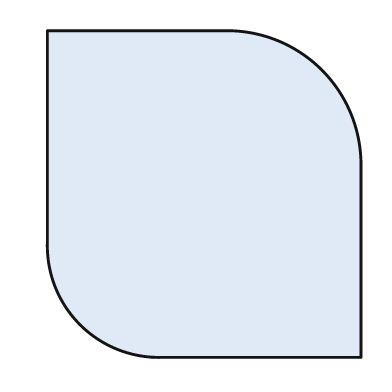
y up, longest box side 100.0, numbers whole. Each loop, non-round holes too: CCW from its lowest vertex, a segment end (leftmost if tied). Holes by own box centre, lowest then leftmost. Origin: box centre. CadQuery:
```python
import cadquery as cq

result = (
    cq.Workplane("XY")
    .moveTo(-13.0, -50.0)
    .lineTo(48.0, -50.0)
    .lineTo(48.0, 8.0)
    .threePointArc((36.0, 38.0), (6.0, 50.0))
    .lineTo(-48.0, 50.0)
    .lineTo(-48.0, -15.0)
    .threePointArc((-38.0, -40.0), (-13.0, -50.0))
    .close()
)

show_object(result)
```